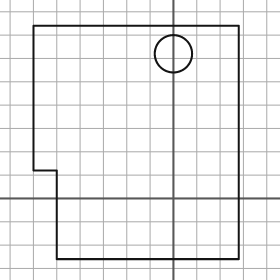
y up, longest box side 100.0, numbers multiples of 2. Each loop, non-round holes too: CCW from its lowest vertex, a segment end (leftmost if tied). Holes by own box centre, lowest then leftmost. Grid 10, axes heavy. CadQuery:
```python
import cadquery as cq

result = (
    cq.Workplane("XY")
    .moveTo(-50.0, -26.0)
    .lineTo(28.0, -26.0)
    .lineTo(28.0, 74.0)
    .lineTo(-60.0, 74.0)
    .lineTo(-60.0, 12.0)
    .lineTo(-50.0, 12.0)
    .close()
    .moveTo(0.0, 62.0)
    .circle(8.0)
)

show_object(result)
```